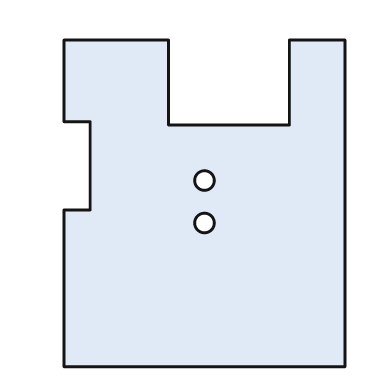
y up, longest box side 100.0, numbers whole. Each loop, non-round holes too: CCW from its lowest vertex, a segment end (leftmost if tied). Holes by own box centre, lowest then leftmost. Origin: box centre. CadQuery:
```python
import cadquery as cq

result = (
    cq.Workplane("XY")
    .moveTo(-43.0, -50.0)
    .lineTo(43.0, -50.0)
    .lineTo(43.0, 50.0)
    .lineTo(26.0, 50.0)
    .lineTo(26.0, 24.0)
    .lineTo(-11.0, 24.0)
    .lineTo(-11.0, 50.0)
    .lineTo(-43.0, 50.0)
    .lineTo(-43.0, 25.0)
    .lineTo(-35.0, 25.0)
    .lineTo(-35.0, -2.0)
    .lineTo(-43.0, -2.0)
    .close()
    .moveTo(0.0, -6.0)
    .circle(3.0)
    .moveTo(0.0, 7.0)
    .circle(3.0)
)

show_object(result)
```